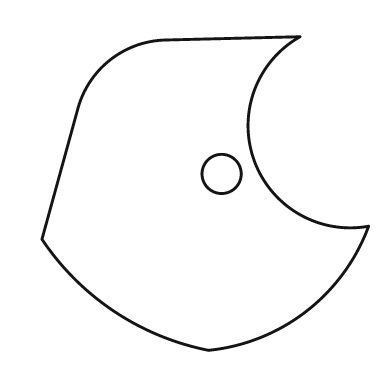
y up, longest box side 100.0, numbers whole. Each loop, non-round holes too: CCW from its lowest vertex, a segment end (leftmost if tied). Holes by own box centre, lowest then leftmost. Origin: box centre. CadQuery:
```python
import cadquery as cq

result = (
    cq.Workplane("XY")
    .moveTo(1.0, -48.0)
    .threePointArc((31.0, -36.0), (50.0, -10.0))
    .threePointArc((15.0, 10.0), (29.0, 48.0))
    .lineTo(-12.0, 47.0)
    .threePointArc((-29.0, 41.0), (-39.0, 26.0))
    .lineTo(-50.0, -14.0)
    .threePointArc((-28.0, -36.0), (1.0, -48.0))
    .close()
    .moveTo(5.0, 6.0)
    .circle(6.0)
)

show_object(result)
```